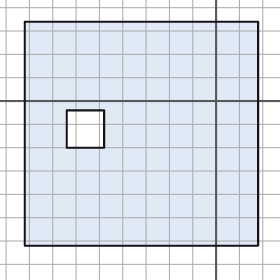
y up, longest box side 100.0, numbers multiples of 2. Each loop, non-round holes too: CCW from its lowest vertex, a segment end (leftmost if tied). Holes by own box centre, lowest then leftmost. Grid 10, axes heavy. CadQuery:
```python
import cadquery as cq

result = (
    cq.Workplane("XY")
    .moveTo(-82.0, -62.0)
    .lineTo(18.0, -62.0)
    .lineTo(18.0, 34.0)
    .lineTo(-82.0, 34.0)
    .close()
    .moveTo(-64.0, -20.0)
    .lineTo(-48.0, -20.0)
    .lineTo(-48.0, -4.0)
    .lineTo(-64.0, -4.0)
    .close()
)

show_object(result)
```